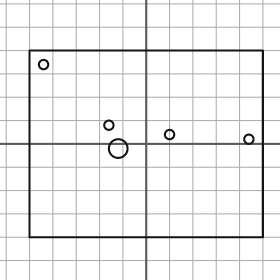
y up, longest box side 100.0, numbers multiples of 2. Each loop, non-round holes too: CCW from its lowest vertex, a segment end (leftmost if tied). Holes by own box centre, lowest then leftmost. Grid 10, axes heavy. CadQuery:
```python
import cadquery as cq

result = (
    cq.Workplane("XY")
    .moveTo(-50.0, -40.0)
    .lineTo(50.0, -40.0)
    .lineTo(50.0, 40.0)
    .lineTo(-50.0, 40.0)
    .close()
    .moveTo(-12.0, -2.0)
    .circle(4.0)
    .moveTo(44.0, 2.0)
    .circle(2.0)
    .moveTo(10.0, 4.0)
    .circle(2.0)
    .moveTo(-16.0, 8.0)
    .circle(2.0)
    .moveTo(-44.0, 34.0)
    .circle(2.0)
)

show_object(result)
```